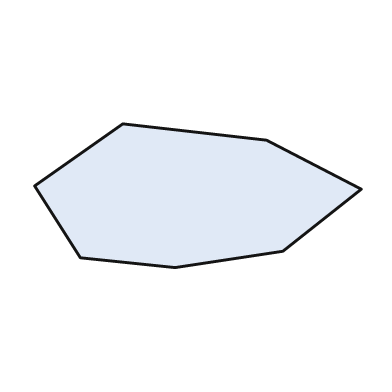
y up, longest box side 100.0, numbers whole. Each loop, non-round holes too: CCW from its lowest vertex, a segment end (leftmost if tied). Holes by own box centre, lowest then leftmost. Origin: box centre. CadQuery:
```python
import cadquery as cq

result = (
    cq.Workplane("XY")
    .moveTo(-7.0, -22.0)
    .lineTo(26.0, -17.0)
    .lineTo(50.0, 2.0)
    .lineTo(21.0, 17.0)
    .lineTo(-23.0, 22.0)
    .lineTo(-50.0, 3.0)
    .lineTo(-36.0, -19.0)
    .close()
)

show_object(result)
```